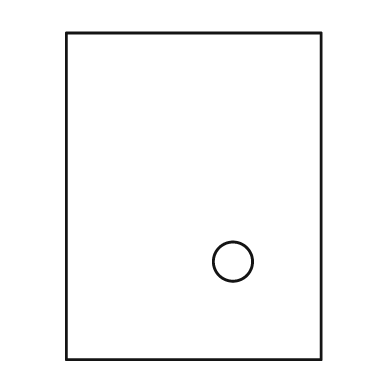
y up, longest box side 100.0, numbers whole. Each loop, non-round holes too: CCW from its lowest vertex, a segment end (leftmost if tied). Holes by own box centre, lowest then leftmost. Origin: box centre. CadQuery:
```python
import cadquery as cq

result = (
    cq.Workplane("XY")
    .moveTo(-39.0, -50.0)
    .lineTo(39.0, -50.0)
    .lineTo(39.0, 50.0)
    .lineTo(-39.0, 50.0)
    .close()
    .moveTo(12.0, -20.0)
    .circle(6.0)
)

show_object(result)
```